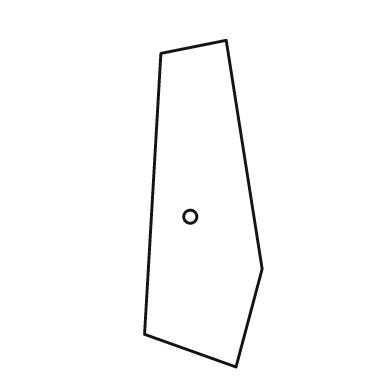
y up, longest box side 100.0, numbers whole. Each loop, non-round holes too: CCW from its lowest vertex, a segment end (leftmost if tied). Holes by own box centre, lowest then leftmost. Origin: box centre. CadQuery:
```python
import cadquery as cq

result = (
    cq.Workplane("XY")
    .moveTo(10.0, -50.0)
    .lineTo(18.0, -20.0)
    .lineTo(7.0, 50.0)
    .lineTo(-13.0, 46.0)
    .lineTo(-18.0, -40.0)
    .close()
    .moveTo(-4.0, -4.0)
    .circle(2.0)
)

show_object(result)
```